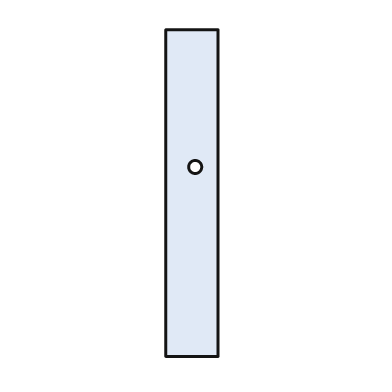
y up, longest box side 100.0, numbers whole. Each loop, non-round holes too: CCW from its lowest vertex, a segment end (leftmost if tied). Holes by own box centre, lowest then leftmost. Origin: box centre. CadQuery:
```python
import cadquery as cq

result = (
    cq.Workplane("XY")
    .moveTo(-8.0, -50.0)
    .lineTo(8.0, -50.0)
    .lineTo(8.0, 50.0)
    .lineTo(-8.0, 50.0)
    .close()
    .moveTo(1.0, 8.0)
    .circle(2.0)
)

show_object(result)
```